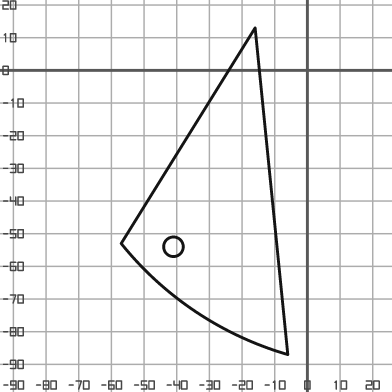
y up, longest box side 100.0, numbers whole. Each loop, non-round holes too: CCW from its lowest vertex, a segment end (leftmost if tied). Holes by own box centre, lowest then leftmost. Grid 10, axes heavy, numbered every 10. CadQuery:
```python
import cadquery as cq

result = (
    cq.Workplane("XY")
    .moveTo(-6.0, -87.0)
    .lineTo(-16.0, 13.0)
    .lineTo(-57.0, -53.0)
    .threePointArc((-34.0, -74.0), (-6.0, -87.0))
    .close()
    .moveTo(-41.0, -54.0)
    .circle(3.0)
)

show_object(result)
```